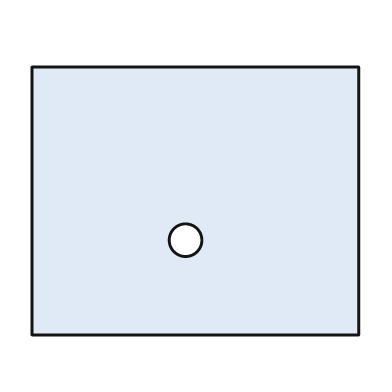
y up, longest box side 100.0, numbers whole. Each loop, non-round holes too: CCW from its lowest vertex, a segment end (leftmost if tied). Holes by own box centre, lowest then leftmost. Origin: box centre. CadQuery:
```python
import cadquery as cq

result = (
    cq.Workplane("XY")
    .moveTo(-50.0, -41.0)
    .lineTo(50.0, -41.0)
    .lineTo(50.0, 41.0)
    .lineTo(-50.0, 41.0)
    .close()
    .moveTo(-3.0, -12.0)
    .circle(5.0)
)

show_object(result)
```